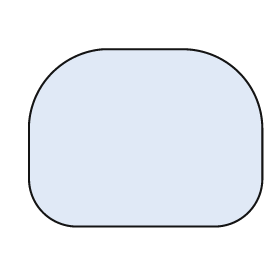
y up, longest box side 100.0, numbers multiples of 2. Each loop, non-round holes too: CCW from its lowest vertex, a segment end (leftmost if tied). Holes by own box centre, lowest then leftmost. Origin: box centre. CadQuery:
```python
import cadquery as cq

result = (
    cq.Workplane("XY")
    .moveTo(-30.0, -38.0)
    .lineTo(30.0, -38.0)
    .threePointArc((44.0, -32.0), (50.0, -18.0))
    .lineTo(50.0, 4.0)
    .threePointArc((40.0, 28.0), (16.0, 38.0))
    .lineTo(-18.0, 38.0)
    .threePointArc((-40.0, 28.0), (-50.0, 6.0))
    .lineTo(-50.0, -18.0)
    .threePointArc((-44.0, -32.0), (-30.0, -38.0))
    .close()
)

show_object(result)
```